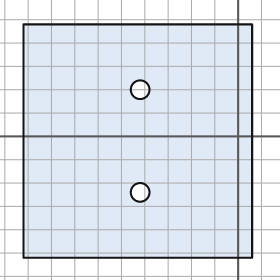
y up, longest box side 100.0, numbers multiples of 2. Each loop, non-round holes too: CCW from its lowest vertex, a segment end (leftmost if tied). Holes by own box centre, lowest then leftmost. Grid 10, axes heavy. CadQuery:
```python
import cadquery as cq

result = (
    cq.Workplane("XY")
    .moveTo(-92.0, -52.0)
    .lineTo(6.0, -52.0)
    .lineTo(6.0, 48.0)
    .lineTo(-92.0, 48.0)
    .close()
    .moveTo(-42.0, -24.0)
    .circle(4.0)
    .moveTo(-42.0, 20.0)
    .circle(4.0)
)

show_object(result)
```